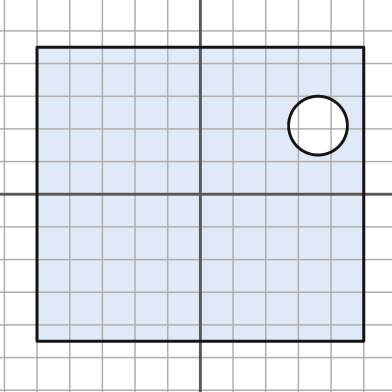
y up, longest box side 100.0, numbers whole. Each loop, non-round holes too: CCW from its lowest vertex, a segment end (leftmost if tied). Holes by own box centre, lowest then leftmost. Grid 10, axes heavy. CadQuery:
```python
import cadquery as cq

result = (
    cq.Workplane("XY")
    .moveTo(-50.0, -45.0)
    .lineTo(50.0, -45.0)
    .lineTo(50.0, 45.0)
    .lineTo(-50.0, 45.0)
    .close()
    .moveTo(36.0, 21.0)
    .circle(9.0)
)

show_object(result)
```